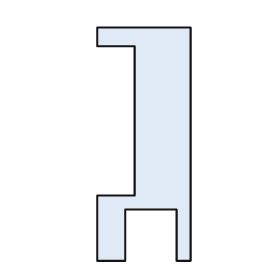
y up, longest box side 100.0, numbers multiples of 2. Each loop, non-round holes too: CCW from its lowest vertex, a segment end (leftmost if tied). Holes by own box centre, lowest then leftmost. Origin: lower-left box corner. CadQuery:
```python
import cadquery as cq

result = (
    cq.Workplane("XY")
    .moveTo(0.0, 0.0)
    .lineTo(12.0, 0.0)
    .lineTo(12.0, 22.0)
    .lineTo(34.0, 22.0)
    .lineTo(34.0, 0.0)
    .lineTo(40.0, 0.0)
    .lineTo(40.0, 100.0)
    .lineTo(0.0, 100.0)
    .lineTo(0.0, 92.0)
    .lineTo(16.0, 92.0)
    .lineTo(16.0, 28.0)
    .lineTo(0.0, 28.0)
    .close()
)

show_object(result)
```